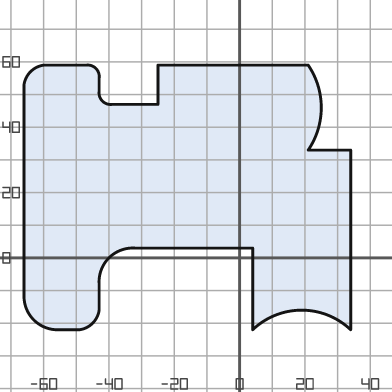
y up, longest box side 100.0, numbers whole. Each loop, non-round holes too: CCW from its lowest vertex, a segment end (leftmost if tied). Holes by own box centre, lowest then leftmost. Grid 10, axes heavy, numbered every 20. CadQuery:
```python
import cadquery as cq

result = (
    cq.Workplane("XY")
    .moveTo(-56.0, -22.0)
    .lineTo(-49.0, -22.0)
    .threePointArc((-45.0, -20.0), (-43.0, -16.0))
    .lineTo(-43.0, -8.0)
    .threePointArc((-40.0, 0.0), (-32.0, 3.0))
    .lineTo(4.0, 3.0)
    .lineTo(4.0, -22.0)
    .threePointArc((19.0, -16.0), (34.0, -22.0))
    .lineTo(34.0, 33.0)
    .lineTo(21.0, 33.0)
    .threePointArc((25.0, 46.0), (21.0, 59.0))
    .lineTo(-25.0, 59.0)
    .lineTo(-25.0, 47.0)
    .lineTo(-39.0, 47.0)
    .threePointArc((-42.0, 48.0), (-43.0, 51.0))
    .lineTo(-43.0, 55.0)
    .threePointArc((-44.0, 58.0), (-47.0, 59.0))
    .lineTo(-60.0, 59.0)
    .threePointArc((-64.0, 57.0), (-66.0, 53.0))
    .lineTo(-66.0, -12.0)
    .threePointArc((-63.0, -19.0), (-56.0, -22.0))
    .close()
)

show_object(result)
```